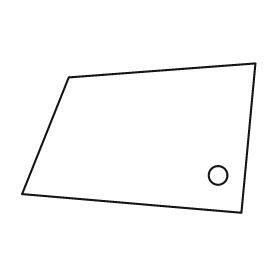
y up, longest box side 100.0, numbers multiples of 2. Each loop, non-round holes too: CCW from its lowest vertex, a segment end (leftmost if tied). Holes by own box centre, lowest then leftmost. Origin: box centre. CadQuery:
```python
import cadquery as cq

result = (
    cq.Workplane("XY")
    .moveTo(44.0, -32.0)
    .lineTo(50.0, 32.0)
    .lineTo(-30.0, 26.0)
    .lineTo(-50.0, -24.0)
    .close()
    .moveTo(34.0, -16.0)
    .circle(4.0)
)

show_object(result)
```